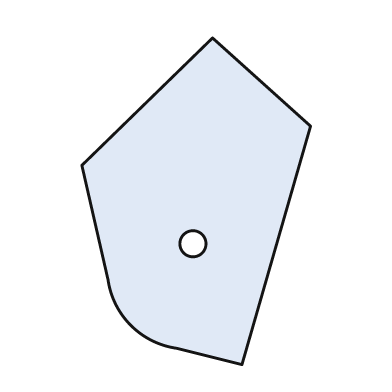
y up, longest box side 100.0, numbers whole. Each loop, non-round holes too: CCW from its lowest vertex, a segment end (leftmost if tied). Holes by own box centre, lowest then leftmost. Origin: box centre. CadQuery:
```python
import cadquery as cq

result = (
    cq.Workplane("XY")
    .moveTo(14.0, -50.0)
    .lineTo(35.0, 23.0)
    .lineTo(5.0, 50.0)
    .lineTo(-35.0, 11.0)
    .lineTo(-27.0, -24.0)
    .threePointArc((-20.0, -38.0), (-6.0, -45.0))
    .close()
    .moveTo(-1.0, -13.0)
    .circle(4.0)
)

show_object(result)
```